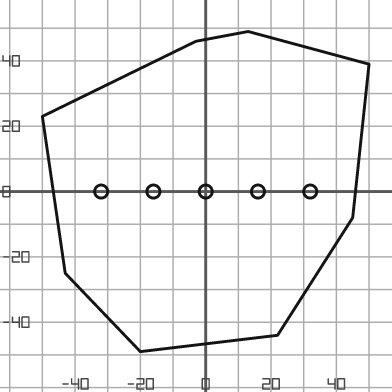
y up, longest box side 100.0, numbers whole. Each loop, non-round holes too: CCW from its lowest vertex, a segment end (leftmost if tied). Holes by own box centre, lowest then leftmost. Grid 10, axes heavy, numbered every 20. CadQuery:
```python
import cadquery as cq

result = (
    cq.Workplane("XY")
    .moveTo(-20.0, -49.0)
    .lineTo(22.0, -44.0)
    .lineTo(45.0, -8.0)
    .lineTo(50.0, 39.0)
    .lineTo(13.0, 49.0)
    .lineTo(-3.0, 46.0)
    .lineTo(-50.0, 23.0)
    .lineTo(-43.0, -25.0)
    .close()
    .moveTo(-32.0, 0.0)
    .circle(2.0)
    .moveTo(-16.0, 0.0)
    .circle(2.0)
    .moveTo(0.0, 0.0)
    .circle(2.0)
    .moveTo(16.0, 0.0)
    .circle(2.0)
    .moveTo(32.0, 0.0)
    .circle(2.0)
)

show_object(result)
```